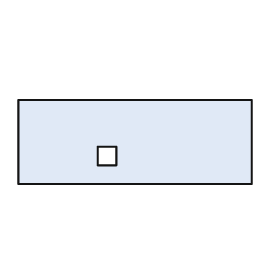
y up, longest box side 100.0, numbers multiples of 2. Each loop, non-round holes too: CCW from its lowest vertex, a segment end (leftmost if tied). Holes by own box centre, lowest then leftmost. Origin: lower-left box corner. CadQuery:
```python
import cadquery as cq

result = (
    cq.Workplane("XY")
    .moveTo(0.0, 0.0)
    .lineTo(100.0, 0.0)
    .lineTo(100.0, 36.0)
    .lineTo(0.0, 36.0)
    .close()
    .moveTo(34.0, 8.0)
    .lineTo(42.0, 8.0)
    .lineTo(42.0, 16.0)
    .lineTo(34.0, 16.0)
    .close()
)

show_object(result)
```